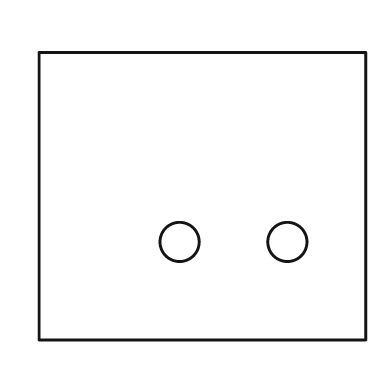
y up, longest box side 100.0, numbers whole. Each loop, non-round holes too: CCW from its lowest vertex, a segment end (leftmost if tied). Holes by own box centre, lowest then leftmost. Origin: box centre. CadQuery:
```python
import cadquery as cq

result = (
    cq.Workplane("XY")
    .moveTo(-50.0, -44.0)
    .lineTo(50.0, -44.0)
    .lineTo(50.0, 44.0)
    .lineTo(-50.0, 44.0)
    .close()
    .moveTo(-7.0, -14.0)
    .circle(6.0)
    .moveTo(26.0, -14.0)
    .circle(6.0)
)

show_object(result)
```